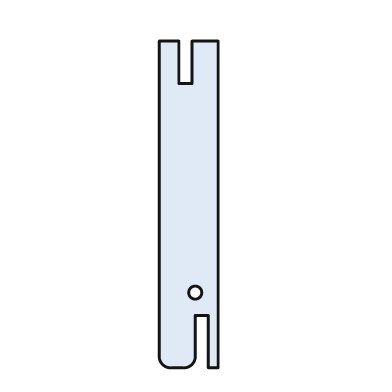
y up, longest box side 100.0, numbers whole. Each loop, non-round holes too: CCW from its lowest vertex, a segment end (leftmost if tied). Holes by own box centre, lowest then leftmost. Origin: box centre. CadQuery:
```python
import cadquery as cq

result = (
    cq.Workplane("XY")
    .moveTo(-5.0, -50.0)
    .lineTo(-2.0, -50.0)
    .threePointArc((1.0, -49.0), (2.0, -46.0))
    .lineTo(2.0, -34.0)
    .lineTo(6.0, -34.0)
    .lineTo(6.0, -50.0)
    .lineTo(9.0, -50.0)
    .lineTo(9.0, 50.0)
    .lineTo(1.0, 50.0)
    .lineTo(1.0, 37.0)
    .lineTo(-3.0, 37.0)
    .lineTo(-3.0, 50.0)
    .lineTo(-9.0, 50.0)
    .lineTo(-9.0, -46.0)
    .threePointArc((-8.0, -49.0), (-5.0, -50.0))
    .close()
    .moveTo(2.0, -27.0)
    .circle(2.0)
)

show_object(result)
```